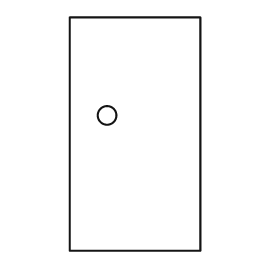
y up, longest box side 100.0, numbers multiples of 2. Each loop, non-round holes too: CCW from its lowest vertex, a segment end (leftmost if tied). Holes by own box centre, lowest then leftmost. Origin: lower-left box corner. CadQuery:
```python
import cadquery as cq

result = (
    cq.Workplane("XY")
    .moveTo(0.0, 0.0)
    .lineTo(56.0, 0.0)
    .lineTo(56.0, 100.0)
    .lineTo(0.0, 100.0)
    .close()
    .moveTo(16.0, 58.0)
    .circle(4.0)
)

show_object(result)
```